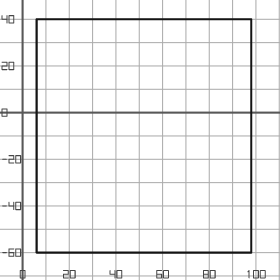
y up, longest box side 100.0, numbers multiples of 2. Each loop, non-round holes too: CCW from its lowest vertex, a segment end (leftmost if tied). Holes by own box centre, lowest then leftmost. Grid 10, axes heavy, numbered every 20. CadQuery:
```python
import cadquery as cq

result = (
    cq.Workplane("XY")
    .moveTo(6.0, -60.0)
    .lineTo(98.0, -60.0)
    .lineTo(98.0, 40.0)
    .lineTo(6.0, 40.0)
    .close()
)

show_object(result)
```